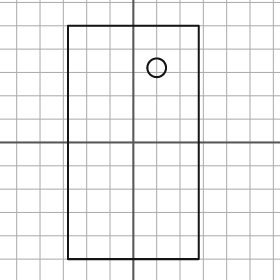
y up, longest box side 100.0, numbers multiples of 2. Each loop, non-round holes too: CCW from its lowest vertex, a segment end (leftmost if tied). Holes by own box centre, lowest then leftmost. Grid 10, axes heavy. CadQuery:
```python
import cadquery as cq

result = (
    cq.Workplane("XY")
    .moveTo(-28.0, -50.0)
    .lineTo(28.0, -50.0)
    .lineTo(28.0, 50.0)
    .lineTo(-28.0, 50.0)
    .close()
    .moveTo(10.0, 32.0)
    .circle(4.0)
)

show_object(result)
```